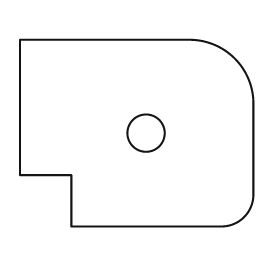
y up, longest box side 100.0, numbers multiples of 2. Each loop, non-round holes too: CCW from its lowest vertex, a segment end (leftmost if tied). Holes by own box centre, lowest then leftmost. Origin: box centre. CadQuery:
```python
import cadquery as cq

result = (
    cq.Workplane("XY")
    .moveTo(-28.0, -40.0)
    .lineTo(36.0, -40.0)
    .threePointArc((46.0, -36.0), (50.0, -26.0))
    .lineTo(50.0, 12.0)
    .threePointArc((42.0, 32.0), (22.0, 40.0))
    .lineTo(-50.0, 40.0)
    .lineTo(-50.0, -18.0)
    .lineTo(-28.0, -18.0)
    .close()
    .moveTo(4.0, 0.0)
    .circle(8.0)
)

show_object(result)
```